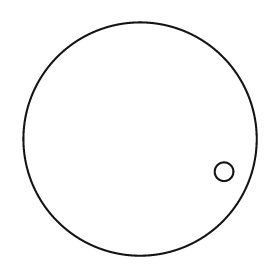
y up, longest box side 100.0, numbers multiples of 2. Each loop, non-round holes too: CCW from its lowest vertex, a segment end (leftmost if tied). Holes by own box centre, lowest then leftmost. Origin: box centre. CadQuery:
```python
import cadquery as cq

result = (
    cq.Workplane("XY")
    .moveTo(0.0, 0.0)
    .circle(50.0)
    .moveTo(36.0, -14.0)
    .circle(4.0)
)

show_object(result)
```